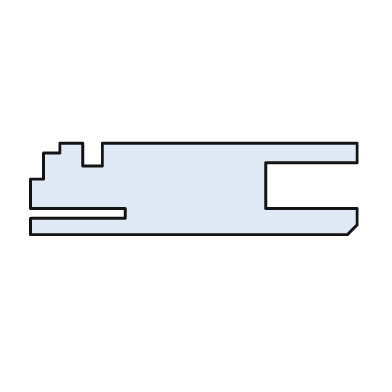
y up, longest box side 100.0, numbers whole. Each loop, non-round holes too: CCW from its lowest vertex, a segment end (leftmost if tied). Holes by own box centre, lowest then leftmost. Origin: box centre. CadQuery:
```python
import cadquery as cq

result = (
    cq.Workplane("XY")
    .moveTo(-50.0, -14.0)
    .lineTo(47.0, -14.0)
    .lineTo(50.0, -11.0)
    .lineTo(50.0, -6.0)
    .lineTo(22.0, -6.0)
    .lineTo(22.0, 8.0)
    .lineTo(50.0, 8.0)
    .lineTo(50.0, 14.0)
    .lineTo(-28.0, 14.0)
    .lineTo(-28.0, 7.0)
    .lineTo(-34.0, 7.0)
    .lineTo(-34.0, 14.0)
    .lineTo(-41.0, 14.0)
    .lineTo(-41.0, 11.0)
    .lineTo(-46.0, 11.0)
    .lineTo(-46.0, 3.0)
    .lineTo(-50.0, 3.0)
    .lineTo(-50.0, -6.0)
    .lineTo(-21.0, -6.0)
    .lineTo(-21.0, -9.0)
    .lineTo(-50.0, -9.0)
    .close()
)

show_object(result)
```